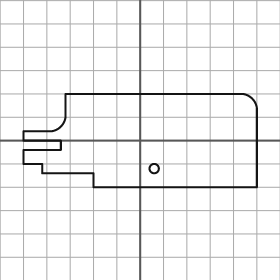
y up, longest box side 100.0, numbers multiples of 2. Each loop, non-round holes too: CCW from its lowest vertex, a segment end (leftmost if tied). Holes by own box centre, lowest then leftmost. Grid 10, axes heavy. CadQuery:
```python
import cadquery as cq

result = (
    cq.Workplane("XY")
    .moveTo(-20.0, -20.0)
    .lineTo(50.0, -20.0)
    .lineTo(50.0, 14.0)
    .threePointArc((48.0, 18.0), (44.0, 20.0))
    .lineTo(-32.0, 20.0)
    .lineTo(-32.0, 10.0)
    .threePointArc((-34.0, 6.0), (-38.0, 4.0))
    .lineTo(-50.0, 4.0)
    .lineTo(-50.0, 0.0)
    .lineTo(-34.0, 0.0)
    .lineTo(-34.0, -4.0)
    .lineTo(-50.0, -4.0)
    .lineTo(-50.0, -10.0)
    .lineTo(-42.0, -10.0)
    .lineTo(-42.0, -14.0)
    .lineTo(-20.0, -14.0)
    .close()
    .moveTo(6.0, -12.0)
    .circle(2.0)
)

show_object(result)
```